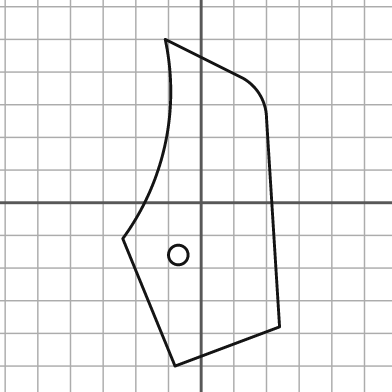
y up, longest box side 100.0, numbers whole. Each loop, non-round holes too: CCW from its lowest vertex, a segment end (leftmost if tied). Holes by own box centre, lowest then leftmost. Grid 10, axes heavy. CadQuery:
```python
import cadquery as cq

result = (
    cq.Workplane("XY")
    .moveTo(-8.0, -50.0)
    .lineTo(24.0, -38.0)
    .lineTo(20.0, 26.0)
    .threePointArc((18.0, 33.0), (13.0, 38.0))
    .lineTo(-11.0, 50.0)
    .threePointArc((-11.0, 18.0), (-24.0, -11.0))
    .close()
    .moveTo(-7.0, -16.0)
    .circle(3.0)
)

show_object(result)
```